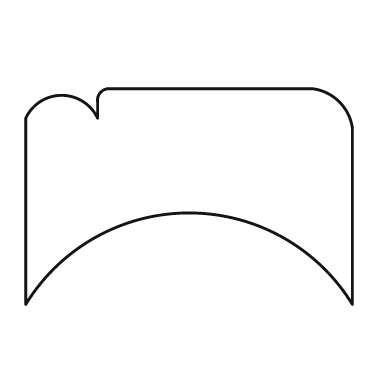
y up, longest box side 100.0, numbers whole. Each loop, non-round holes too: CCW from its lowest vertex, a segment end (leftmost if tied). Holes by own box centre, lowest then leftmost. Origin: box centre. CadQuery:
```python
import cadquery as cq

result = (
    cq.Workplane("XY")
    .moveTo(-50.0, -33.0)
    .threePointArc((0.0, -5.0), (50.0, -33.0))
    .lineTo(50.0, 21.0)
    .threePointArc((46.0, 29.0), (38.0, 33.0))
    .lineTo(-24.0, 33.0)
    .threePointArc((-27.0, 32.0), (-28.0, 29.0))
    .lineTo(-28.0, 24.0)
    .threePointArc((-39.0, 31.0), (-50.0, 24.0))
    .close()
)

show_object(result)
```